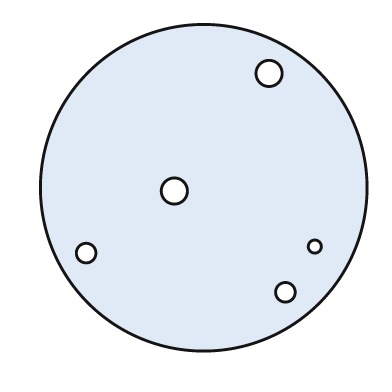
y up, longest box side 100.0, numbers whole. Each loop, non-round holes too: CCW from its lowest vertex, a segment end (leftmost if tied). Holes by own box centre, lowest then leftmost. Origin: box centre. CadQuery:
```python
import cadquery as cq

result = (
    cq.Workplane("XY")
    .moveTo(0.0, 0.0)
    .circle(50.0)
    .moveTo(25.0, -32.0)
    .circle(3.0)
    .moveTo(-36.0, -20.0)
    .circle(3.0)
    .moveTo(34.0, -18.0)
    .circle(2.0)
    .moveTo(-9.0, -1.0)
    .circle(4.0)
    .moveTo(20.0, 35.0)
    .circle(4.0)
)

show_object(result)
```